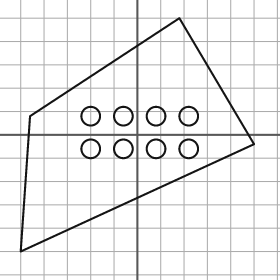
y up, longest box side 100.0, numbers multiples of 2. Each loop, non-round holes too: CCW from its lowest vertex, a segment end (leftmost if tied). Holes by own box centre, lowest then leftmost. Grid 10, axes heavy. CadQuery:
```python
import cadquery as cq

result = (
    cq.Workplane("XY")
    .moveTo(-50.0, -50.0)
    .lineTo(50.0, -4.0)
    .lineTo(18.0, 50.0)
    .lineTo(-46.0, 8.0)
    .close()
    .moveTo(-20.0, -6.0)
    .circle(4.0)
    .moveTo(-6.0, -6.0)
    .circle(4.0)
    .moveTo(8.0, -6.0)
    .circle(4.0)
    .moveTo(22.0, -6.0)
    .circle(4.0)
    .moveTo(-20.0, 8.0)
    .circle(4.0)
    .moveTo(-6.0, 8.0)
    .circle(4.0)
    .moveTo(8.0, 8.0)
    .circle(4.0)
    .moveTo(22.0, 8.0)
    .circle(4.0)
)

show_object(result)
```